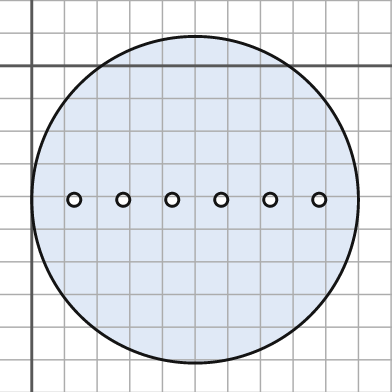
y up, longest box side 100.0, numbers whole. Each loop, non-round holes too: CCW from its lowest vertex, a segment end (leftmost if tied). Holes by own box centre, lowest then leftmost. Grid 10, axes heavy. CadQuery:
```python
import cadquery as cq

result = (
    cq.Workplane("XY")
    .moveTo(50.0, -41.0)
    .circle(50.0)
    .moveTo(13.0, -41.0)
    .circle(2.0)
    .moveTo(28.0, -41.0)
    .circle(2.0)
    .moveTo(43.0, -41.0)
    .circle(2.0)
    .moveTo(58.0, -41.0)
    .circle(2.0)
    .moveTo(73.0, -41.0)
    .circle(2.0)
    .moveTo(88.0, -41.0)
    .circle(2.0)
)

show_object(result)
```